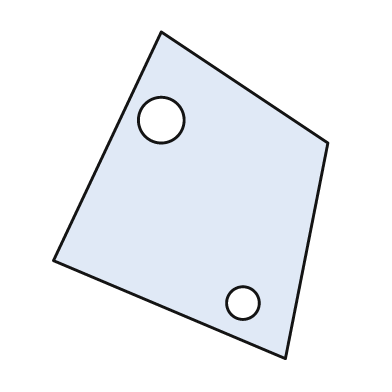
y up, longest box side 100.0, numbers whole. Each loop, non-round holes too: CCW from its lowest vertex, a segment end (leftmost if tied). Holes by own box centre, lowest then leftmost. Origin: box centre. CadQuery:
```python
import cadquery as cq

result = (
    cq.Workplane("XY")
    .moveTo(29.0, -50.0)
    .lineTo(42.0, 16.0)
    .lineTo(-9.0, 50.0)
    .lineTo(-42.0, -20.0)
    .close()
    .moveTo(16.0, -33.0)
    .circle(5.0)
    .moveTo(-9.0, 23.0)
    .circle(7.0)
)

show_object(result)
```